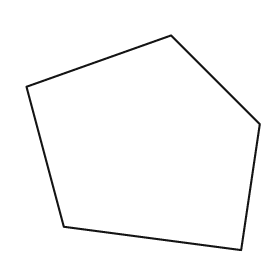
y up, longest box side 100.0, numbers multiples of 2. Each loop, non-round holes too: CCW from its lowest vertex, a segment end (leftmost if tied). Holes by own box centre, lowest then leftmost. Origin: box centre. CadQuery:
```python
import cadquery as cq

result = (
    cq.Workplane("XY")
    .moveTo(42.0, -46.0)
    .lineTo(50.0, 8.0)
    .lineTo(12.0, 46.0)
    .lineTo(-50.0, 24.0)
    .lineTo(-34.0, -36.0)
    .close()
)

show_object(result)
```